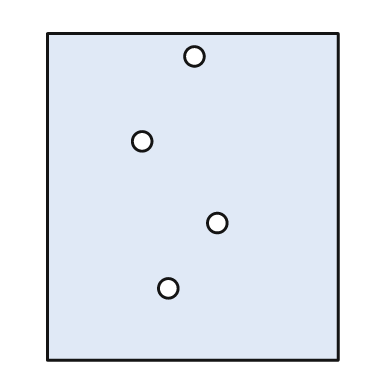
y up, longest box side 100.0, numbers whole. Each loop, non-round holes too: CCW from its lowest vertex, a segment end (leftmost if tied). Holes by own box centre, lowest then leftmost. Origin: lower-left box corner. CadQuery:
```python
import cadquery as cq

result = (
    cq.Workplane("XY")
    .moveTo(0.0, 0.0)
    .lineTo(89.0, 0.0)
    .lineTo(89.0, 100.0)
    .lineTo(0.0, 100.0)
    .close()
    .moveTo(37.0, 22.0)
    .circle(3.0)
    .moveTo(52.0, 42.0)
    .circle(3.0)
    .moveTo(29.0, 67.0)
    .circle(3.0)
    .moveTo(45.0, 93.0)
    .circle(3.0)
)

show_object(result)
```